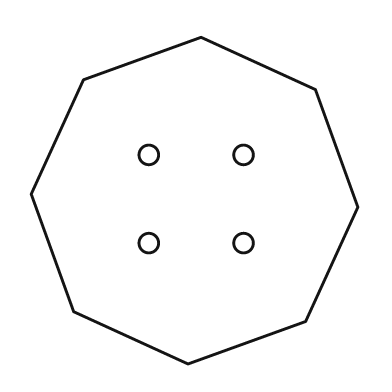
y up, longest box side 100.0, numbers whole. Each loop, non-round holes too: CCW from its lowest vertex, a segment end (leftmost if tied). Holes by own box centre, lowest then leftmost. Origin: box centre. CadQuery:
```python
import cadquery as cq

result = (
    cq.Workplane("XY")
    .moveTo(-2.0, -50.0)
    .lineTo(34.0, -37.0)
    .lineTo(50.0, -2.0)
    .lineTo(37.0, 34.0)
    .lineTo(2.0, 50.0)
    .lineTo(-34.0, 37.0)
    .lineTo(-50.0, 2.0)
    .lineTo(-37.0, -34.0)
    .close()
    .moveTo(-14.0, -13.0)
    .circle(3.0)
    .moveTo(15.0, -13.0)
    .circle(3.0)
    .moveTo(-14.0, 14.0)
    .circle(3.0)
    .moveTo(15.0, 14.0)
    .circle(3.0)
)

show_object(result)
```